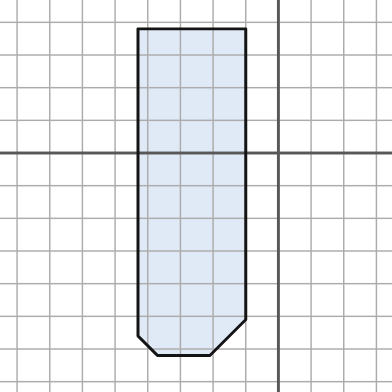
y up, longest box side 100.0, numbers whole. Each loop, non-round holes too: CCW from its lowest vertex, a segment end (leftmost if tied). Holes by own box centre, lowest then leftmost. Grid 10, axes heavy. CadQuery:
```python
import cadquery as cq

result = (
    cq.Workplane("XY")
    .moveTo(-37.0, -62.0)
    .lineTo(-21.0, -62.0)
    .lineTo(-10.0, -51.0)
    .lineTo(-10.0, 38.0)
    .lineTo(-43.0, 38.0)
    .lineTo(-43.0, -56.0)
    .close()
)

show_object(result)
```